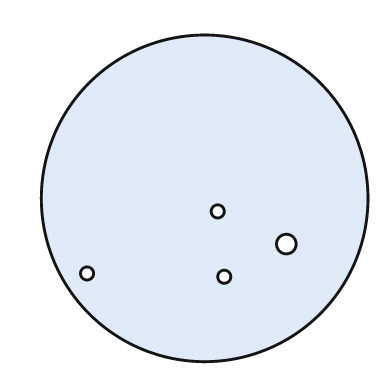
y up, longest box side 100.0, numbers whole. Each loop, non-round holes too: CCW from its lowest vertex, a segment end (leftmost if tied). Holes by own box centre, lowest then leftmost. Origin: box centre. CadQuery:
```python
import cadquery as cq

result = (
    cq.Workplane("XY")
    .moveTo(0.0, 0.0)
    .circle(50.0)
    .moveTo(6.0, -24.0)
    .circle(2.0)
    .moveTo(-36.0, -23.0)
    .circle(2.0)
    .moveTo(25.0, -14.0)
    .circle(3.0)
    .moveTo(4.0, -4.0)
    .circle(2.0)
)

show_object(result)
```